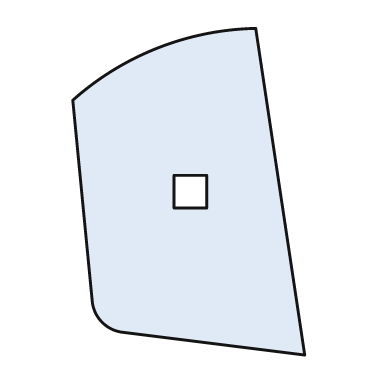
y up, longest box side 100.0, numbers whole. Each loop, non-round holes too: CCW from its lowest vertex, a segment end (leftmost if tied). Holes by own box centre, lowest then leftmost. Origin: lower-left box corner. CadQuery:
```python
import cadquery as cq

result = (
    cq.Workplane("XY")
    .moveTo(71.0, 0.0)
    .lineTo(56.0, 100.0)
    .threePointArc((26.0, 94.0), (0.0, 78.0))
    .lineTo(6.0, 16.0)
    .threePointArc((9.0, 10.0), (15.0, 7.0))
    .close()
    .moveTo(31.0, 45.0)
    .lineTo(41.0, 45.0)
    .lineTo(41.0, 55.0)
    .lineTo(31.0, 55.0)
    .close()
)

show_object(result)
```